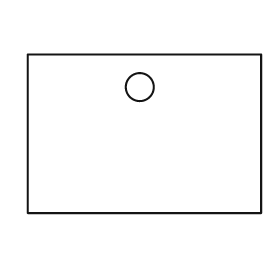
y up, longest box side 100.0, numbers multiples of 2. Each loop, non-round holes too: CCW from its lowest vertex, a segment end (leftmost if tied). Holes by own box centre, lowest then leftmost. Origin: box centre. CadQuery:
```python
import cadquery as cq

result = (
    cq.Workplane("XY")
    .moveTo(-50.0, -34.0)
    .lineTo(50.0, -34.0)
    .lineTo(50.0, 34.0)
    .lineTo(-50.0, 34.0)
    .close()
    .moveTo(-2.0, 20.0)
    .circle(6.0)
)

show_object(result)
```